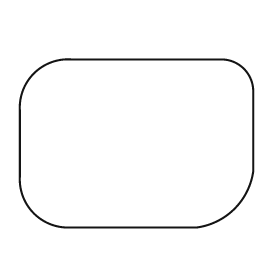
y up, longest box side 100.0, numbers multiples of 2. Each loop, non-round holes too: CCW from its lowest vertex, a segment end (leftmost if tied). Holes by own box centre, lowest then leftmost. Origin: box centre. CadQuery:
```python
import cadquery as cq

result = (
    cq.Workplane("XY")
    .moveTo(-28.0, -36.0)
    .lineTo(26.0, -36.0)
    .threePointArc((42.0, -28.0), (50.0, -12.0))
    .lineTo(50.0, 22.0)
    .threePointArc((46.0, 32.0), (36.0, 36.0))
    .lineTo(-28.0, 36.0)
    .threePointArc((-44.0, 30.0), (-50.0, 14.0))
    .lineTo(-50.0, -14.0)
    .threePointArc((-44.0, -30.0), (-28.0, -36.0))
    .close()
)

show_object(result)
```